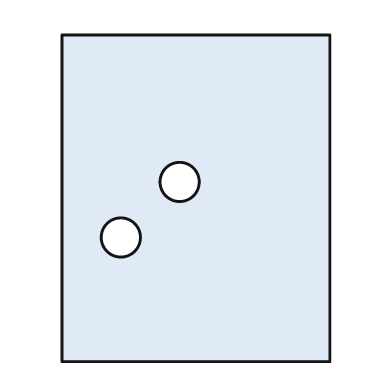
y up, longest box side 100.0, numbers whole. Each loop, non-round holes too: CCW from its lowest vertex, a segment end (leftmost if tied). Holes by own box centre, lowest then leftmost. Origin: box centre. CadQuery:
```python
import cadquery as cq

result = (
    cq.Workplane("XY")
    .moveTo(-41.0, -50.0)
    .lineTo(41.0, -50.0)
    .lineTo(41.0, 50.0)
    .lineTo(-41.0, 50.0)
    .close()
    .moveTo(-23.0, -12.0)
    .circle(6.0)
    .moveTo(-5.0, 5.0)
    .circle(6.0)
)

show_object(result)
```